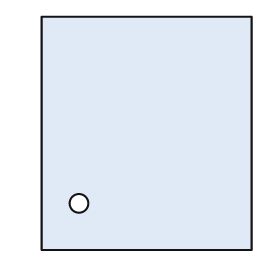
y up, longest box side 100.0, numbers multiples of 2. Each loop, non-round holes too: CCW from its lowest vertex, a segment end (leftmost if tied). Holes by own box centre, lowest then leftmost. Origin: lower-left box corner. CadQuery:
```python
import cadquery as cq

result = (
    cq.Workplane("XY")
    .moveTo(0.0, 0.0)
    .lineTo(90.0, 0.0)
    .lineTo(90.0, 100.0)
    .lineTo(0.0, 100.0)
    .close()
    .moveTo(16.0, 20.0)
    .circle(4.0)
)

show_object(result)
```